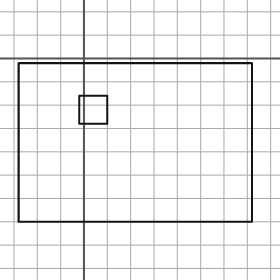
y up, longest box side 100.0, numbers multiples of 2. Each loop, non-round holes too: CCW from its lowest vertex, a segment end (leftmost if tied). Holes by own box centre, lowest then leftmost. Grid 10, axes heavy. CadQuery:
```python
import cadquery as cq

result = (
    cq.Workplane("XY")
    .moveTo(-28.0, -70.0)
    .lineTo(72.0, -70.0)
    .lineTo(72.0, -2.0)
    .lineTo(-28.0, -2.0)
    .close()
    .moveTo(-2.0, -28.0)
    .lineTo(10.0, -28.0)
    .lineTo(10.0, -16.0)
    .lineTo(-2.0, -16.0)
    .close()
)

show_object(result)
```